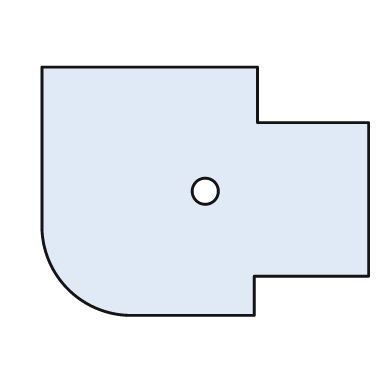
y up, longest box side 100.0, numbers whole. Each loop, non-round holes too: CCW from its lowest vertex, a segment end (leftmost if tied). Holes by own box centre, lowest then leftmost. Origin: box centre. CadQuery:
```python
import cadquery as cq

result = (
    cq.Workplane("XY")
    .moveTo(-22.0, -38.0)
    .lineTo(15.0, -38.0)
    .lineTo(15.0, -26.0)
    .lineTo(50.0, -26.0)
    .lineTo(50.0, 21.0)
    .lineTo(16.0, 21.0)
    .lineTo(16.0, 38.0)
    .lineTo(-50.0, 38.0)
    .lineTo(-50.0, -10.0)
    .threePointArc((-42.0, -30.0), (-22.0, -38.0))
    .close()
    .moveTo(0.0, 0.0)
    .circle(4.0)
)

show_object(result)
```